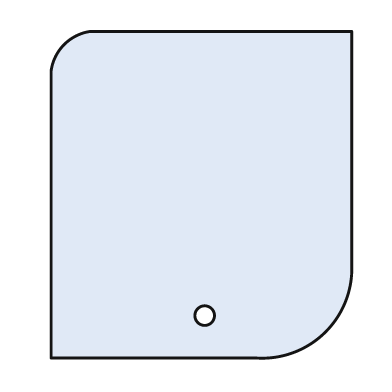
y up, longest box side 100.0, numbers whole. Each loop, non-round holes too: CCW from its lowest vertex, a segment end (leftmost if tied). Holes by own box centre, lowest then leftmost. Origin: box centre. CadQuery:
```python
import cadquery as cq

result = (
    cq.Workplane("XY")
    .moveTo(-46.0, -50.0)
    .lineTo(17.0, -50.0)
    .threePointArc((38.0, -42.0), (46.0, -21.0))
    .lineTo(46.0, 50.0)
    .lineTo(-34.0, 50.0)
    .threePointArc((-42.0, 46.0), (-46.0, 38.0))
    .close()
    .moveTo(1.0, -37.0)
    .circle(3.0)
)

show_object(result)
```